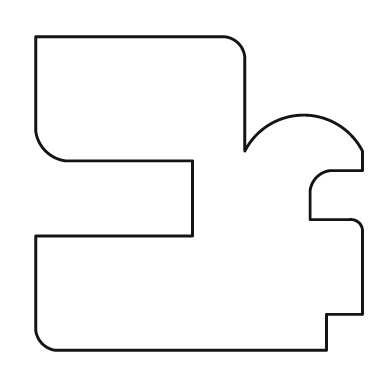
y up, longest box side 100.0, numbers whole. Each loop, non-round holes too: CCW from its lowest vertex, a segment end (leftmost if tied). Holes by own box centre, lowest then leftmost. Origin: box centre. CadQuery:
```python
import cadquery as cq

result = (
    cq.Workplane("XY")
    .moveTo(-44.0, -48.0)
    .lineTo(39.0, -48.0)
    .lineTo(39.0, -37.0)
    .lineTo(50.0, -37.0)
    .lineTo(50.0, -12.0)
    .threePointArc((49.0, -9.0), (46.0, -8.0))
    .lineTo(34.0, -8.0)
    .lineTo(34.0, 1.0)
    .threePointArc((36.0, 5.0), (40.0, 7.0))
    .lineTo(50.0, 7.0)
    .lineTo(50.0, 13.0)
    .threePointArc((32.0, 24.0), (14.0, 13.0))
    .lineTo(14.0, 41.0)
    .threePointArc((12.0, 46.0), (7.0, 48.0))
    .lineTo(-50.0, 48.0)
    .lineTo(-50.0, 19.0)
    .threePointArc((-47.0, 13.0), (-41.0, 10.0))
    .lineTo(-2.0, 10.0)
    .lineTo(-2.0, -13.0)
    .lineTo(-50.0, -13.0)
    .lineTo(-50.0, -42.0)
    .threePointArc((-48.0, -46.0), (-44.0, -48.0))
    .close()
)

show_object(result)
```